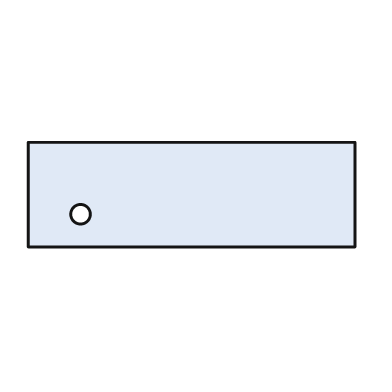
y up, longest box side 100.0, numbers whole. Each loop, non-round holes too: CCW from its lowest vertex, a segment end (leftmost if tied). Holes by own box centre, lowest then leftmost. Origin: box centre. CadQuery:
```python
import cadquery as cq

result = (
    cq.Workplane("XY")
    .moveTo(-50.0, -16.0)
    .lineTo(50.0, -16.0)
    .lineTo(50.0, 16.0)
    .lineTo(-50.0, 16.0)
    .close()
    .moveTo(-34.0, -6.0)
    .circle(3.0)
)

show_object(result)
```